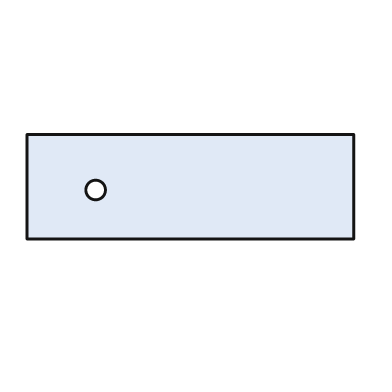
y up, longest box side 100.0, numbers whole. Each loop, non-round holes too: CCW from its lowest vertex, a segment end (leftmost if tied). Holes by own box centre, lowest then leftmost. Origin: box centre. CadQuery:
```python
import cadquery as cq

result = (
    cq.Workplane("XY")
    .moveTo(-50.0, -16.0)
    .lineTo(50.0, -16.0)
    .lineTo(50.0, 16.0)
    .lineTo(-50.0, 16.0)
    .close()
    .moveTo(-29.0, -1.0)
    .circle(3.0)
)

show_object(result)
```